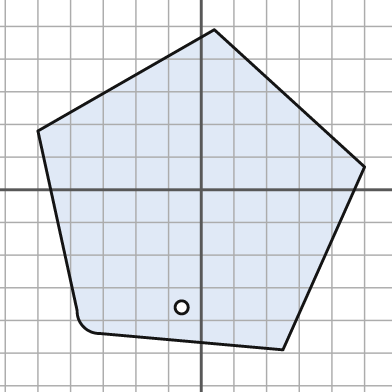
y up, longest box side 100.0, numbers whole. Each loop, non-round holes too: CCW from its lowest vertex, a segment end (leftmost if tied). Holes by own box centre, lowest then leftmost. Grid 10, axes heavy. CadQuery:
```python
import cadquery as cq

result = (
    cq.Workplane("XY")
    .moveTo(25.0, -49.0)
    .lineTo(50.0, 7.0)
    .lineTo(4.0, 49.0)
    .lineTo(-50.0, 18.0)
    .lineTo(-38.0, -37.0)
    .threePointArc((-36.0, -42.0), (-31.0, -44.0))
    .close()
    .moveTo(-6.0, -36.0)
    .circle(2.0)
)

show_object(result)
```